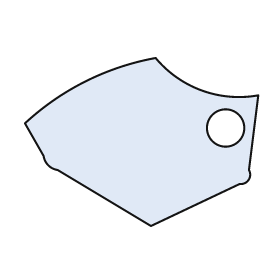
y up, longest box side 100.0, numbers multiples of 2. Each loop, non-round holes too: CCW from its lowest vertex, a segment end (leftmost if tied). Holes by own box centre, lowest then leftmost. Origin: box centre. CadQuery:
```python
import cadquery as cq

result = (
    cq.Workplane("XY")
    .moveTo(4.0, -36.0)
    .lineTo(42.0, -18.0)
    .threePointArc((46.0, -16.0), (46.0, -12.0))
    .lineTo(50.0, 20.0)
    .threePointArc((26.0, 22.0), (6.0, 36.0))
    .threePointArc((-24.0, 26.0), (-50.0, 8.0))
    .lineTo(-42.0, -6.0)
    .threePointArc((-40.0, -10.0), (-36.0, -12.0))
    .close()
    .moveTo(36.0, 6.0)
    .circle(8.0)
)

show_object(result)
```